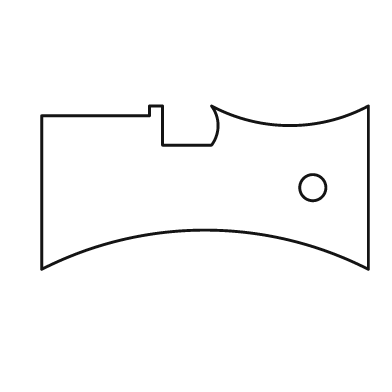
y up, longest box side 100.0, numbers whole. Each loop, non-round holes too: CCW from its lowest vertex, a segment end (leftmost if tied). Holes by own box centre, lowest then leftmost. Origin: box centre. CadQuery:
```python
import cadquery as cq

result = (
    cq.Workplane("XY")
    .moveTo(-50.0, -25.0)
    .threePointArc((0.0, -13.0), (50.0, -25.0))
    .lineTo(50.0, 25.0)
    .threePointArc((26.0, 19.0), (2.0, 25.0))
    .threePointArc((4.0, 19.0), (2.0, 13.0))
    .lineTo(-13.0, 13.0)
    .lineTo(-13.0, 25.0)
    .lineTo(-17.0, 25.0)
    .lineTo(-17.0, 22.0)
    .lineTo(-50.0, 22.0)
    .close()
    .moveTo(33.0, 0.0)
    .circle(4.0)
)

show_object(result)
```